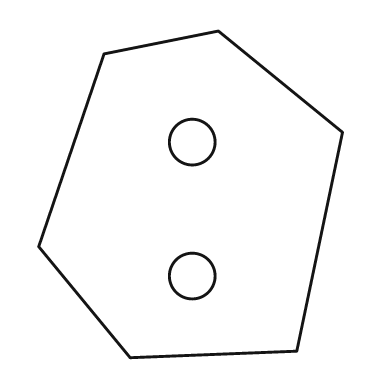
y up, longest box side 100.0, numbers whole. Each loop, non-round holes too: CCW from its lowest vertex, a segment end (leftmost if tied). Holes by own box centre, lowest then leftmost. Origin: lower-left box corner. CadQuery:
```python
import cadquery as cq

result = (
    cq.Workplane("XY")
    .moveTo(28.0, 0.0)
    .lineTo(79.0, 2.0)
    .lineTo(93.0, 69.0)
    .lineTo(55.0, 100.0)
    .lineTo(20.0, 93.0)
    .lineTo(0.0, 34.0)
    .close()
    .moveTo(47.0, 25.0)
    .circle(7.0)
    .moveTo(47.0, 66.0)
    .circle(7.0)
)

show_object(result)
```